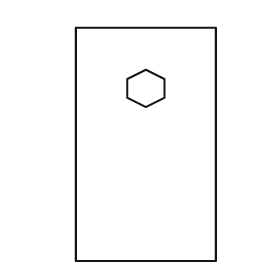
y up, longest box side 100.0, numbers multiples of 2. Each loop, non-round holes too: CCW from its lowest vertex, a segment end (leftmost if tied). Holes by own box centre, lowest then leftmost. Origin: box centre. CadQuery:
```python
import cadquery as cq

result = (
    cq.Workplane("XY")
    .moveTo(-30.0, -50.0)
    .lineTo(30.0, -50.0)
    .lineTo(30.0, 50.0)
    .lineTo(-30.0, 50.0)
    .close()
    .moveTo(0.0, 16.0)
    .lineTo(8.0, 20.0)
    .lineTo(8.0, 28.0)
    .lineTo(0.0, 32.0)
    .lineTo(-8.0, 28.0)
    .lineTo(-8.0, 20.0)
    .close()
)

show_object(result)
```